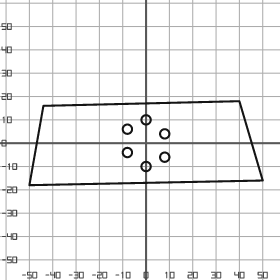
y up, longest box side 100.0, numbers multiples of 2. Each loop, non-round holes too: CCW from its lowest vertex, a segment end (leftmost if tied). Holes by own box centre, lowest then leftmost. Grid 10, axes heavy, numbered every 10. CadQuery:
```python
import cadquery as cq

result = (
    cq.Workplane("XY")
    .moveTo(-50.0, -18.0)
    .lineTo(50.0, -16.0)
    .lineTo(40.0, 18.0)
    .lineTo(-44.0, 16.0)
    .close()
    .moveTo(0.0, -10.0)
    .circle(2.0)
    .moveTo(8.0, -6.0)
    .circle(2.0)
    .moveTo(-8.0, -4.0)
    .circle(2.0)
    .moveTo(8.0, 4.0)
    .circle(2.0)
    .moveTo(-8.0, 6.0)
    .circle(2.0)
    .moveTo(0.0, 10.0)
    .circle(2.0)
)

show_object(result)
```